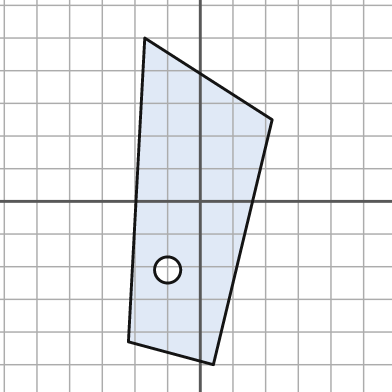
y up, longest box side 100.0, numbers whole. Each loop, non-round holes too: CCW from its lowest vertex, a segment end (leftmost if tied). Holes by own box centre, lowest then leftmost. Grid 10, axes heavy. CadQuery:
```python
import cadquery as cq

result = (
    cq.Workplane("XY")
    .moveTo(4.0, -50.0)
    .lineTo(22.0, 25.0)
    .lineTo(-17.0, 50.0)
    .lineTo(-22.0, -43.0)
    .close()
    .moveTo(-10.0, -21.0)
    .circle(4.0)
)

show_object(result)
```